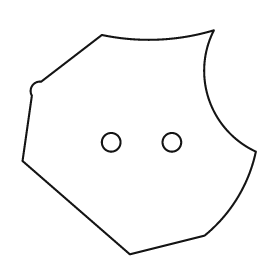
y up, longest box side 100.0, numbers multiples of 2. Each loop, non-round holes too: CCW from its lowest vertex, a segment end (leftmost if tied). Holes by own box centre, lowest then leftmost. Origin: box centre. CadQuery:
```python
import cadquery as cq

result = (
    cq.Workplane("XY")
    .moveTo(-4.0, -48.0)
    .lineTo(28.0, -40.0)
    .threePointArc((42.0, -24.0), (50.0, -4.0))
    .threePointArc((30.0, 18.0), (32.0, 48.0))
    .threePointArc((8.0, 44.0), (-16.0, 46.0))
    .lineTo(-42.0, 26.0)
    .threePointArc((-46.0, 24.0), (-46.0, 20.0))
    .lineTo(-50.0, -8.0)
    .close()
    .moveTo(-12.0, 0.0)
    .circle(4.0)
    .moveTo(14.0, 0.0)
    .circle(4.0)
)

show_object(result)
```